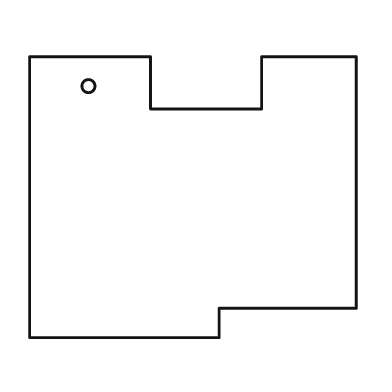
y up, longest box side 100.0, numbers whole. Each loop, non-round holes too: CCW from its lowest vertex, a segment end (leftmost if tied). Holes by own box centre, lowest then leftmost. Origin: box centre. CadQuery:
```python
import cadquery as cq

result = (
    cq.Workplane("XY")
    .moveTo(-50.0, -43.0)
    .lineTo(8.0, -43.0)
    .lineTo(8.0, -34.0)
    .lineTo(50.0, -34.0)
    .lineTo(50.0, 43.0)
    .lineTo(21.0, 43.0)
    .lineTo(21.0, 27.0)
    .lineTo(-13.0, 27.0)
    .lineTo(-13.0, 43.0)
    .lineTo(-50.0, 43.0)
    .close()
    .moveTo(-32.0, 34.0)
    .circle(2.0)
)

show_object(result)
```